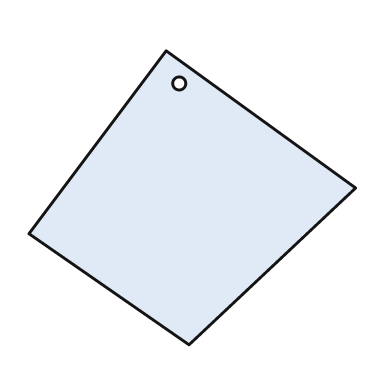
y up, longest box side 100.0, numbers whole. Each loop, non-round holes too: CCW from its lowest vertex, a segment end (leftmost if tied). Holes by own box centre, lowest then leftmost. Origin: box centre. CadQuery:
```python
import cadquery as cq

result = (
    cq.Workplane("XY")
    .moveTo(-1.0, -45.0)
    .lineTo(50.0, 3.0)
    .lineTo(-8.0, 45.0)
    .lineTo(-50.0, -11.0)
    .close()
    .moveTo(-4.0, 35.0)
    .circle(2.0)
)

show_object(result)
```